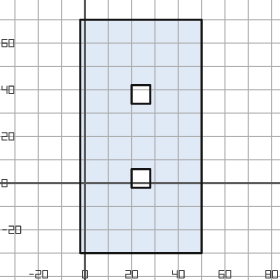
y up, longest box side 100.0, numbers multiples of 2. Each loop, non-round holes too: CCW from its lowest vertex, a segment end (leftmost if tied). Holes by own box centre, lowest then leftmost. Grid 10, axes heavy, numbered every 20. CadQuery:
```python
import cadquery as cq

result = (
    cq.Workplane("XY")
    .moveTo(-2.0, -30.0)
    .lineTo(50.0, -30.0)
    .lineTo(50.0, 70.0)
    .lineTo(-2.0, 70.0)
    .close()
    .moveTo(20.0, -2.0)
    .lineTo(28.0, -2.0)
    .lineTo(28.0, 6.0)
    .lineTo(20.0, 6.0)
    .close()
    .moveTo(20.0, 34.0)
    .lineTo(28.0, 34.0)
    .lineTo(28.0, 42.0)
    .lineTo(20.0, 42.0)
    .close()
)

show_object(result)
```